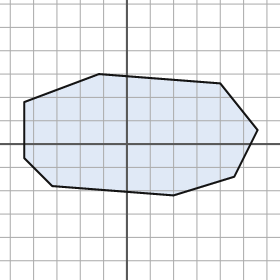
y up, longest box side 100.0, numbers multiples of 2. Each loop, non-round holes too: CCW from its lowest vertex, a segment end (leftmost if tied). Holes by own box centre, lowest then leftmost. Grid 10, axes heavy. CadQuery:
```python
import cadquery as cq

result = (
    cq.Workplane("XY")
    .moveTo(20.0, -22.0)
    .lineTo(46.0, -14.0)
    .lineTo(56.0, 6.0)
    .lineTo(40.0, 26.0)
    .lineTo(-12.0, 30.0)
    .lineTo(-44.0, 18.0)
    .lineTo(-44.0, -6.0)
    .lineTo(-32.0, -18.0)
    .close()
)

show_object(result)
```